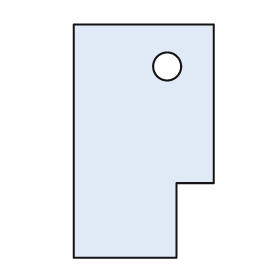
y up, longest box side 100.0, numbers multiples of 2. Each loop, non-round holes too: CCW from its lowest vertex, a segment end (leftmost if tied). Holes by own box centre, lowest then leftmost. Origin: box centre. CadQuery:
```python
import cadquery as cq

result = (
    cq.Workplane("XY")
    .moveTo(-30.0, -50.0)
    .lineTo(14.0, -50.0)
    .lineTo(14.0, -18.0)
    .lineTo(30.0, -18.0)
    .lineTo(30.0, 50.0)
    .lineTo(-30.0, 50.0)
    .close()
    .moveTo(10.0, 32.0)
    .circle(6.0)
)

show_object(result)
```